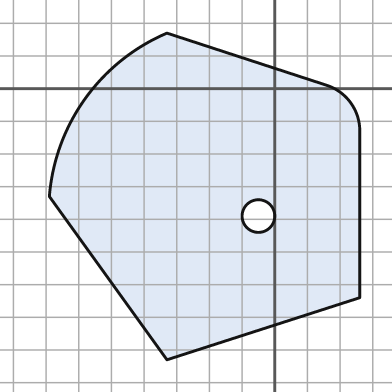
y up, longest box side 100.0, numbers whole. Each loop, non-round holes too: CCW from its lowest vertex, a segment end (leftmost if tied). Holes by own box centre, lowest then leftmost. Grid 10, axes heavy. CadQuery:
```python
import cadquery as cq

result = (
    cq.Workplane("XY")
    .moveTo(-33.0, -83.0)
    .lineTo(26.0, -64.0)
    .lineTo(26.0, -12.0)
    .threePointArc((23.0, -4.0), (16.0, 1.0))
    .lineTo(-33.0, 17.0)
    .threePointArc((-58.0, -3.0), (-69.0, -33.0))
    .close()
    .moveTo(-5.0, -39.0)
    .circle(5.0)
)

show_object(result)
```